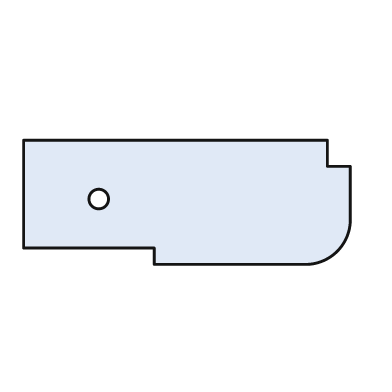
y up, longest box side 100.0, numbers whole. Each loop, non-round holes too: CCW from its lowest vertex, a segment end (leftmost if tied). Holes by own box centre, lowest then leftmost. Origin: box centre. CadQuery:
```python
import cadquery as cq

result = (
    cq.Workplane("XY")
    .moveTo(-10.0, -19.0)
    .lineTo(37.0, -19.0)
    .threePointArc((46.0, -15.0), (50.0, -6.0))
    .lineTo(50.0, 11.0)
    .lineTo(43.0, 11.0)
    .lineTo(43.0, 19.0)
    .lineTo(-50.0, 19.0)
    .lineTo(-50.0, -14.0)
    .lineTo(-10.0, -14.0)
    .close()
    .moveTo(-27.0, 1.0)
    .circle(3.0)
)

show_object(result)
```